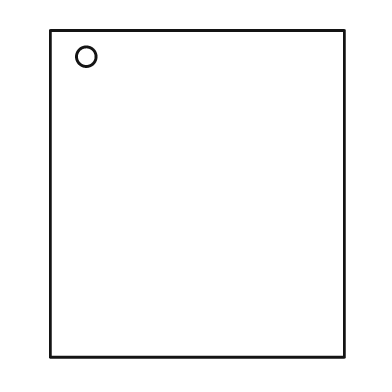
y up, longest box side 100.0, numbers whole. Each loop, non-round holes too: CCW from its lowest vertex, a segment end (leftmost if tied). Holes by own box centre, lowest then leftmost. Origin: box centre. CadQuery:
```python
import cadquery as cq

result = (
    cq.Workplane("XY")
    .moveTo(-45.0, -50.0)
    .lineTo(45.0, -50.0)
    .lineTo(45.0, 50.0)
    .lineTo(-45.0, 50.0)
    .close()
    .moveTo(-34.0, 42.0)
    .circle(3.0)
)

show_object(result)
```